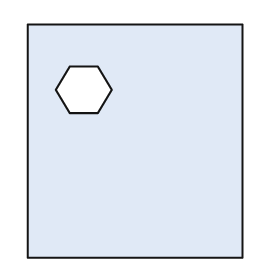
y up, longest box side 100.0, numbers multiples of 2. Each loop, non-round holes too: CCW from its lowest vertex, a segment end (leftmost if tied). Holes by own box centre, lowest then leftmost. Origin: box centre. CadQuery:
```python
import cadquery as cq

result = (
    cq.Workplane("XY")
    .moveTo(-46.0, -50.0)
    .lineTo(46.0, -50.0)
    .lineTo(46.0, 50.0)
    .lineTo(-46.0, 50.0)
    .close()
    .moveTo(-28.0, 12.0)
    .lineTo(-16.0, 12.0)
    .lineTo(-10.0, 22.0)
    .lineTo(-16.0, 32.0)
    .lineTo(-28.0, 32.0)
    .lineTo(-34.0, 22.0)
    .close()
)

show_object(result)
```